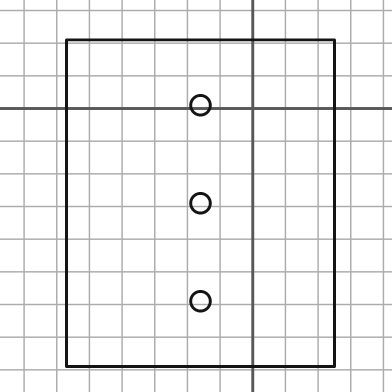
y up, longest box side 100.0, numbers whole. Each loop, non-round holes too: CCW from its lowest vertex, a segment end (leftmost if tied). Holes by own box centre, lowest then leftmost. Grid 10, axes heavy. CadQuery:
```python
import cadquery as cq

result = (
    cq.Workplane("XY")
    .moveTo(-57.0, -79.0)
    .lineTo(25.0, -79.0)
    .lineTo(25.0, 21.0)
    .lineTo(-57.0, 21.0)
    .close()
    .moveTo(-16.0, -59.0)
    .circle(3.0)
    .moveTo(-16.0, -29.0)
    .circle(3.0)
    .moveTo(-16.0, 1.0)
    .circle(3.0)
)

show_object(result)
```